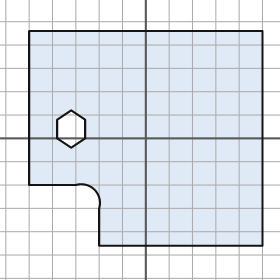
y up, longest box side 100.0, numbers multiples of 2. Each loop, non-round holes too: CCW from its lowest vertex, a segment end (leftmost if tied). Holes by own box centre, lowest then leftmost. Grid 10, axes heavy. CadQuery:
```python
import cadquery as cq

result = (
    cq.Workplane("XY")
    .moveTo(-20.0, -46.0)
    .lineTo(50.0, -46.0)
    .lineTo(50.0, 46.0)
    .lineTo(-50.0, 46.0)
    .lineTo(-50.0, -20.0)
    .lineTo(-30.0, -20.0)
    .threePointArc((-22.0, -22.0), (-20.0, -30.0))
    .close()
    .moveTo(-32.0, -4.0)
    .lineTo(-26.0, 0.0)
    .lineTo(-26.0, 8.0)
    .lineTo(-32.0, 12.0)
    .lineTo(-38.0, 8.0)
    .lineTo(-38.0, 0.0)
    .close()
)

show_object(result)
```